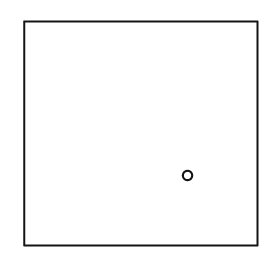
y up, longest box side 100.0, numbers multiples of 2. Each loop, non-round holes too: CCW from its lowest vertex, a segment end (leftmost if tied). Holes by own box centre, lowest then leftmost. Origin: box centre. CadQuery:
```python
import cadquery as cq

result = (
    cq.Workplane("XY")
    .moveTo(-50.0, -48.0)
    .lineTo(50.0, -48.0)
    .lineTo(50.0, 48.0)
    .lineTo(-50.0, 48.0)
    .close()
    .moveTo(20.0, -18.0)
    .circle(2.0)
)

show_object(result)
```